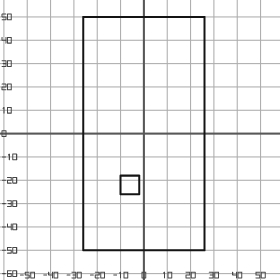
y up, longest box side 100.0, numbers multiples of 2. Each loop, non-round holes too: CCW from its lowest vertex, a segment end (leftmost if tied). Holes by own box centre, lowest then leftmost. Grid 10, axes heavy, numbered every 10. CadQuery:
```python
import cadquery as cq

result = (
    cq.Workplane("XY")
    .moveTo(-26.0, -50.0)
    .lineTo(26.0, -50.0)
    .lineTo(26.0, 50.0)
    .lineTo(-26.0, 50.0)
    .close()
    .moveTo(-10.0, -26.0)
    .lineTo(-2.0, -26.0)
    .lineTo(-2.0, -18.0)
    .lineTo(-10.0, -18.0)
    .close()
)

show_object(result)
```